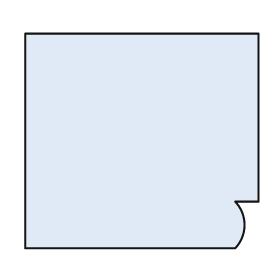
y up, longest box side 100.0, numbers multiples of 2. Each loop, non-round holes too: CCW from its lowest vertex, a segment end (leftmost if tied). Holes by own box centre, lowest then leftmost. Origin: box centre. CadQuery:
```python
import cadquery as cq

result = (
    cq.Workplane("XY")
    .moveTo(-50.0, -46.0)
    .lineTo(40.0, -46.0)
    .threePointArc((44.0, -36.0), (40.0, -26.0))
    .lineTo(50.0, -26.0)
    .lineTo(50.0, 46.0)
    .lineTo(-50.0, 46.0)
    .close()
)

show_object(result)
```